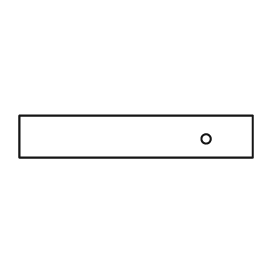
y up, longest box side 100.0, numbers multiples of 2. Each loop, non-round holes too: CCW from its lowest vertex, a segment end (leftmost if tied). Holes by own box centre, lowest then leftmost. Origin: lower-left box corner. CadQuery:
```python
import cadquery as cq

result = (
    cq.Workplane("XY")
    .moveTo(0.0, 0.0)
    .lineTo(100.0, 0.0)
    .lineTo(100.0, 18.0)
    .lineTo(0.0, 18.0)
    .close()
    .moveTo(80.0, 8.0)
    .circle(2.0)
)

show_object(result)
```